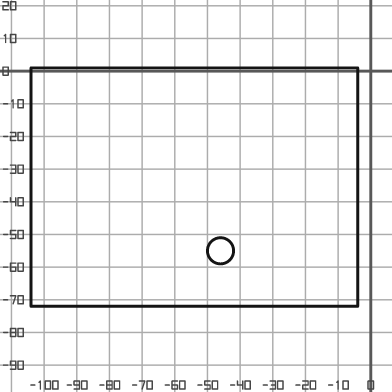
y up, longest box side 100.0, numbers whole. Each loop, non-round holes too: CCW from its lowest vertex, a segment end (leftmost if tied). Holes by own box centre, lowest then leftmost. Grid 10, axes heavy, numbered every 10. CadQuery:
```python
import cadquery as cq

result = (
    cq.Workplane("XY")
    .moveTo(-104.0, -72.0)
    .lineTo(-4.0, -72.0)
    .lineTo(-4.0, 1.0)
    .lineTo(-104.0, 1.0)
    .close()
    .moveTo(-46.0, -55.0)
    .circle(4.0)
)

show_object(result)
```